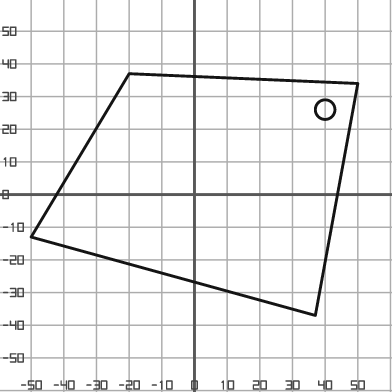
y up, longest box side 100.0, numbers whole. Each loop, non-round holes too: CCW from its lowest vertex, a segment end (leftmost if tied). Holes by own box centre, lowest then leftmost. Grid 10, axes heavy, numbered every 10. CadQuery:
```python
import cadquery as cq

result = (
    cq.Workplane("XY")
    .moveTo(37.0, -37.0)
    .lineTo(50.0, 34.0)
    .lineTo(-20.0, 37.0)
    .lineTo(-50.0, -13.0)
    .close()
    .moveTo(40.0, 26.0)
    .circle(3.0)
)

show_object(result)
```